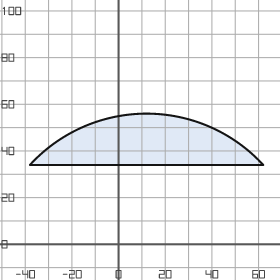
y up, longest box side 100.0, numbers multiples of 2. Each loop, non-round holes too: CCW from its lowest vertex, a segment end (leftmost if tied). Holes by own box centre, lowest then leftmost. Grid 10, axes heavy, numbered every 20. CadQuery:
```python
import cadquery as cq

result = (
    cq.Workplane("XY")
    .moveTo(-38.0, 34.0)
    .lineTo(62.0, 34.0)
    .threePointArc((12.0, 56.0), (-38.0, 34.0))
    .close()
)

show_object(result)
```